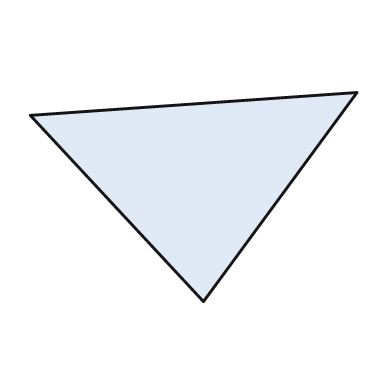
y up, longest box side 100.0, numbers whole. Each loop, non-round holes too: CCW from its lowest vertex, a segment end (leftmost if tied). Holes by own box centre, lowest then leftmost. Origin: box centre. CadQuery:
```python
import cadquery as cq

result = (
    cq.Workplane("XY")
    .moveTo(3.0, -32.0)
    .lineTo(50.0, 32.0)
    .lineTo(-50.0, 25.0)
    .close()
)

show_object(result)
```